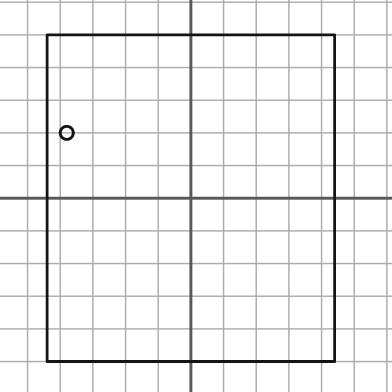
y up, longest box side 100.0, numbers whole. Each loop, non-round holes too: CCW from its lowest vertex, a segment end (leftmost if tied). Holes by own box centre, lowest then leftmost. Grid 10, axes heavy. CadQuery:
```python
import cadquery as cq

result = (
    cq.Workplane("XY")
    .moveTo(-44.0, -50.0)
    .lineTo(44.0, -50.0)
    .lineTo(44.0, 50.0)
    .lineTo(-44.0, 50.0)
    .close()
    .moveTo(-38.0, 20.0)
    .circle(2.0)
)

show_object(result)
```